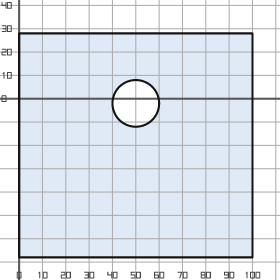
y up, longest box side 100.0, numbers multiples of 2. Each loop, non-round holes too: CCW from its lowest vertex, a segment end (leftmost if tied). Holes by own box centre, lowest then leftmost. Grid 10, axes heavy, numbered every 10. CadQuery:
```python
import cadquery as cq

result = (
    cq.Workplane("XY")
    .moveTo(0.0, -68.0)
    .lineTo(100.0, -68.0)
    .lineTo(100.0, 28.0)
    .lineTo(0.0, 28.0)
    .close()
    .moveTo(50.0, -2.0)
    .circle(10.0)
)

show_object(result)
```